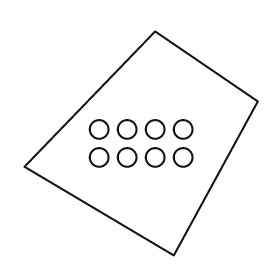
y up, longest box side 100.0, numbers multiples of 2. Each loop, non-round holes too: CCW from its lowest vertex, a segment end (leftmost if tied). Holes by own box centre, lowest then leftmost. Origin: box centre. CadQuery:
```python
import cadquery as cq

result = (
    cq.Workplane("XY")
    .moveTo(14.0, -48.0)
    .lineTo(50.0, 18.0)
    .lineTo(6.0, 48.0)
    .lineTo(-50.0, -10.0)
    .close()
    .moveTo(-18.0, -6.0)
    .circle(4.0)
    .moveTo(-6.0, -6.0)
    .circle(4.0)
    .moveTo(6.0, -6.0)
    .circle(4.0)
    .moveTo(18.0, -6.0)
    .circle(4.0)
    .moveTo(-18.0, 6.0)
    .circle(4.0)
    .moveTo(-6.0, 6.0)
    .circle(4.0)
    .moveTo(6.0, 6.0)
    .circle(4.0)
    .moveTo(18.0, 6.0)
    .circle(4.0)
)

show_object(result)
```